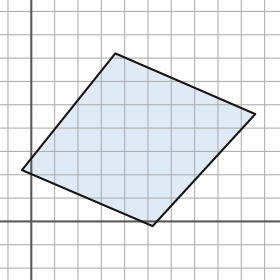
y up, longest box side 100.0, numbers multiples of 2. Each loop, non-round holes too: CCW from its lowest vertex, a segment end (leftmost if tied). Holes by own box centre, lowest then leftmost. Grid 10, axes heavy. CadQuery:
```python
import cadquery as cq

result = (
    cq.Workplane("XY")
    .moveTo(52.0, -2.0)
    .lineTo(96.0, 46.0)
    .lineTo(36.0, 72.0)
    .lineTo(-4.0, 22.0)
    .close()
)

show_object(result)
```